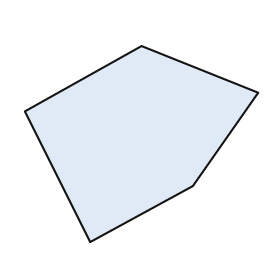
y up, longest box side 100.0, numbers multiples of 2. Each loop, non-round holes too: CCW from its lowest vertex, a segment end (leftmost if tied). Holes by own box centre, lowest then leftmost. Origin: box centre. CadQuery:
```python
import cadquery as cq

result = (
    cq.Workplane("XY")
    .moveTo(-22.0, -42.0)
    .lineTo(22.0, -18.0)
    .lineTo(50.0, 22.0)
    .lineTo(0.0, 42.0)
    .lineTo(-50.0, 14.0)
    .close()
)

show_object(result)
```